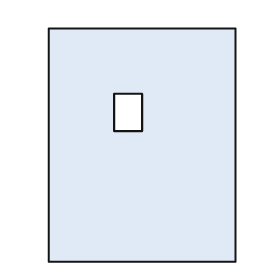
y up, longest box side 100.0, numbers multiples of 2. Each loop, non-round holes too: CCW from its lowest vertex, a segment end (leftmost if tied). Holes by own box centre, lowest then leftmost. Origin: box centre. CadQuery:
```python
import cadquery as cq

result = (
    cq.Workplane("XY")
    .moveTo(-40.0, -50.0)
    .lineTo(40.0, -50.0)
    .lineTo(40.0, 50.0)
    .lineTo(-40.0, 50.0)
    .close()
    .moveTo(-12.0, 6.0)
    .lineTo(0.0, 6.0)
    .lineTo(0.0, 22.0)
    .lineTo(-12.0, 22.0)
    .close()
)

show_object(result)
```